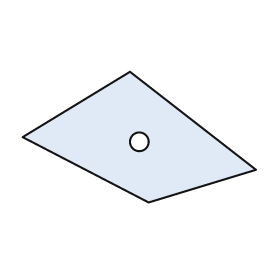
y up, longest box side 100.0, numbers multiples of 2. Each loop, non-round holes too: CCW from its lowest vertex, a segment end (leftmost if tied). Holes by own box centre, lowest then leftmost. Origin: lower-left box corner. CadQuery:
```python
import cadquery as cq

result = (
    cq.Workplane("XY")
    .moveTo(54.0, 0.0)
    .lineTo(100.0, 14.0)
    .lineTo(46.0, 56.0)
    .lineTo(0.0, 28.0)
    .close()
    .moveTo(50.0, 26.0)
    .circle(4.0)
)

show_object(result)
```